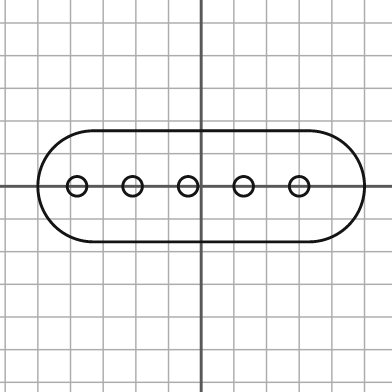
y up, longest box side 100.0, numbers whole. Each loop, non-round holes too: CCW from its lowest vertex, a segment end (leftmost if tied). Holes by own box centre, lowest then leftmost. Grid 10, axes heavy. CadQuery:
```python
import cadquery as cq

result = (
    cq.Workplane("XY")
    .moveTo(-33.0, -17.0)
    .lineTo(33.0, -17.0)
    .threePointArc((50.0, 0.0), (33.0, 17.0))
    .lineTo(-33.0, 17.0)
    .threePointArc((-50.0, 0.0), (-33.0, -17.0))
    .close()
    .moveTo(-38.0, 0.0)
    .circle(3.0)
    .moveTo(-21.0, 0.0)
    .circle(3.0)
    .moveTo(-4.0, 0.0)
    .circle(3.0)
    .moveTo(13.0, 0.0)
    .circle(3.0)
    .moveTo(30.0, 0.0)
    .circle(3.0)
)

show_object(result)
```